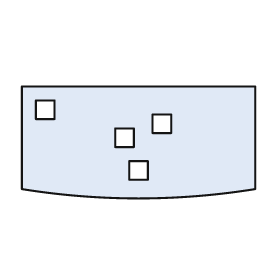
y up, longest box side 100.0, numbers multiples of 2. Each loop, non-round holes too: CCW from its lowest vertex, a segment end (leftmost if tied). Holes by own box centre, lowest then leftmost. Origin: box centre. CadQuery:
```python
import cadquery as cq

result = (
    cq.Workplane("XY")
    .moveTo(-50.0, -20.0)
    .threePointArc((0.0, -24.0), (50.0, -20.0))
    .lineTo(50.0, 24.0)
    .lineTo(-50.0, 24.0)
    .close()
    .moveTo(-4.0, -16.0)
    .lineTo(4.0, -16.0)
    .lineTo(4.0, -8.0)
    .lineTo(-4.0, -8.0)
    .close()
    .moveTo(-10.0, -2.0)
    .lineTo(-2.0, -2.0)
    .lineTo(-2.0, 6.0)
    .lineTo(-10.0, 6.0)
    .close()
    .moveTo(6.0, 4.0)
    .lineTo(14.0, 4.0)
    .lineTo(14.0, 12.0)
    .lineTo(6.0, 12.0)
    .close()
    .moveTo(-44.0, 10.0)
    .lineTo(-36.0, 10.0)
    .lineTo(-36.0, 18.0)
    .lineTo(-44.0, 18.0)
    .close()
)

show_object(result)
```